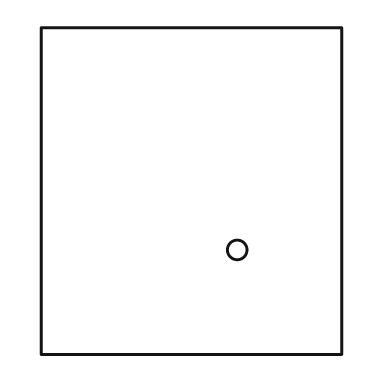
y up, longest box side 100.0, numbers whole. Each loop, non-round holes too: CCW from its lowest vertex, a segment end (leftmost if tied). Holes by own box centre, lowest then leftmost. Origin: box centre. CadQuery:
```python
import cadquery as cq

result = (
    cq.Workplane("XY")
    .moveTo(-46.0, -50.0)
    .lineTo(46.0, -50.0)
    .lineTo(46.0, 50.0)
    .lineTo(-46.0, 50.0)
    .close()
    .moveTo(14.0, -18.0)
    .circle(3.0)
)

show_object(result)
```